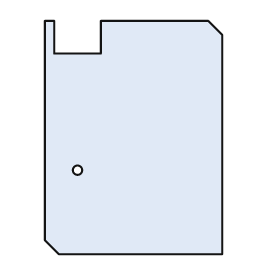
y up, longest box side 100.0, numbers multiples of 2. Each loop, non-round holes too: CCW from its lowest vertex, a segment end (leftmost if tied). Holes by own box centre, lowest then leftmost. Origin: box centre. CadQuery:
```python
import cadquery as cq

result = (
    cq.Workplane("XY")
    .moveTo(-32.0, -50.0)
    .lineTo(38.0, -50.0)
    .lineTo(38.0, 44.0)
    .lineTo(32.0, 50.0)
    .lineTo(-14.0, 50.0)
    .lineTo(-14.0, 36.0)
    .lineTo(-34.0, 36.0)
    .lineTo(-34.0, 50.0)
    .lineTo(-38.0, 50.0)
    .lineTo(-38.0, -44.0)
    .close()
    .moveTo(-24.0, -14.0)
    .circle(2.0)
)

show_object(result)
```